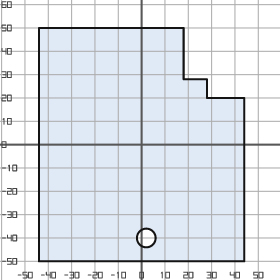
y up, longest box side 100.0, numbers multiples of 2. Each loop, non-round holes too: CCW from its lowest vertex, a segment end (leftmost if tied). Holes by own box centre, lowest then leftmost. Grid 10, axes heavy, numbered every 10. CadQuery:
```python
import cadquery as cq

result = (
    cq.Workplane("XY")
    .moveTo(-44.0, -50.0)
    .lineTo(44.0, -50.0)
    .lineTo(44.0, 20.0)
    .lineTo(28.0, 20.0)
    .lineTo(28.0, 28.0)
    .lineTo(18.0, 28.0)
    .lineTo(18.0, 50.0)
    .lineTo(-44.0, 50.0)
    .close()
    .moveTo(2.0, -40.0)
    .circle(4.0)
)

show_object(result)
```